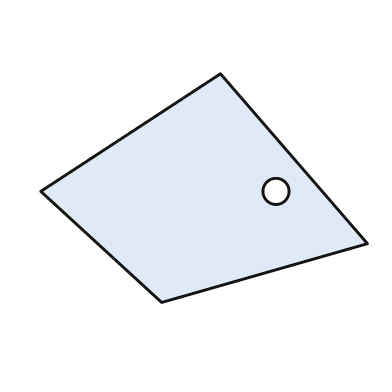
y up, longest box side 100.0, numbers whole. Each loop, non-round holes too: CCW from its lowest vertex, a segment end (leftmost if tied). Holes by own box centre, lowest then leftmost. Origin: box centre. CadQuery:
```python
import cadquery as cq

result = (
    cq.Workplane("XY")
    .moveTo(-13.0, -35.0)
    .lineTo(50.0, -17.0)
    .lineTo(5.0, 35.0)
    .lineTo(-50.0, -1.0)
    .close()
    .moveTo(22.0, -1.0)
    .circle(4.0)
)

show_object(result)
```